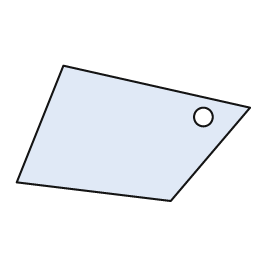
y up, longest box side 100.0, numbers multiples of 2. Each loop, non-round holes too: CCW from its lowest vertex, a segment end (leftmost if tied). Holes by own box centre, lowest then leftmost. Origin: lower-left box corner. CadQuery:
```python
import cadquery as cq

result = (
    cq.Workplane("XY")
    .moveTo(66.0, 0.0)
    .lineTo(100.0, 40.0)
    .lineTo(20.0, 58.0)
    .lineTo(0.0, 8.0)
    .close()
    .moveTo(80.0, 36.0)
    .circle(4.0)
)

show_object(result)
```